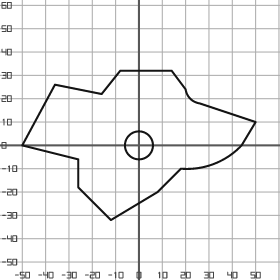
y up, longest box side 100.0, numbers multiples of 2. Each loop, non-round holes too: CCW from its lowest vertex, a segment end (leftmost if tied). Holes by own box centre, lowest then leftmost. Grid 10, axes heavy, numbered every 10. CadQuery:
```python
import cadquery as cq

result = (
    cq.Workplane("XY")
    .moveTo(-12.0, -32.0)
    .lineTo(8.0, -20.0)
    .lineTo(18.0, -10.0)
    .threePointArc((32.0, -8.0), (44.0, 0.0))
    .lineTo(50.0, 10.0)
    .lineTo(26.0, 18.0)
    .threePointArc((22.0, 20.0), (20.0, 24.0))
    .lineTo(14.0, 32.0)
    .lineTo(-8.0, 32.0)
    .lineTo(-16.0, 22.0)
    .lineTo(-36.0, 26.0)
    .lineTo(-50.0, 0.0)
    .lineTo(-26.0, -6.0)
    .lineTo(-26.0, -18.0)
    .close()
    .moveTo(0.0, 0.0)
    .circle(6.0)
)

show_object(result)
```